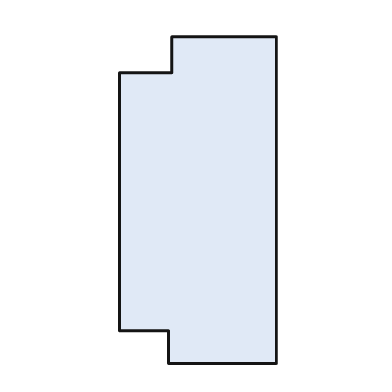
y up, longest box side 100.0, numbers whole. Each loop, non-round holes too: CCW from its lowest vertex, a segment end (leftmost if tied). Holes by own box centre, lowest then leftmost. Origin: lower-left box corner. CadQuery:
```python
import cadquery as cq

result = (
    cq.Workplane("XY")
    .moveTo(15.0, 0.0)
    .lineTo(48.0, 0.0)
    .lineTo(48.0, 100.0)
    .lineTo(16.0, 100.0)
    .lineTo(16.0, 89.0)
    .lineTo(0.0, 89.0)
    .lineTo(0.0, 10.0)
    .lineTo(15.0, 10.0)
    .close()
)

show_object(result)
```